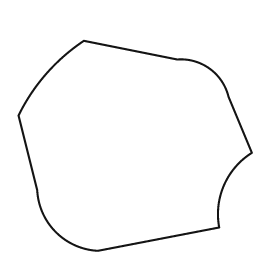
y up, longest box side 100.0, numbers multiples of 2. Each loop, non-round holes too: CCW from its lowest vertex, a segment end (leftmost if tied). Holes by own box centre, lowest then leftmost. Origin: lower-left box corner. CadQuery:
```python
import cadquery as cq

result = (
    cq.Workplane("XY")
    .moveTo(34.0, 0.0)
    .lineTo(86.0, 10.0)
    .threePointArc((88.0, 28.0), (100.0, 42.0))
    .lineTo(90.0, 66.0)
    .threePointArc((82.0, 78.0), (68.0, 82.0))
    .lineTo(28.0, 90.0)
    .threePointArc((12.0, 76.0), (0.0, 58.0))
    .lineTo(8.0, 26.0)
    .threePointArc((16.0, 8.0), (34.0, 0.0))
    .close()
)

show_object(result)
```